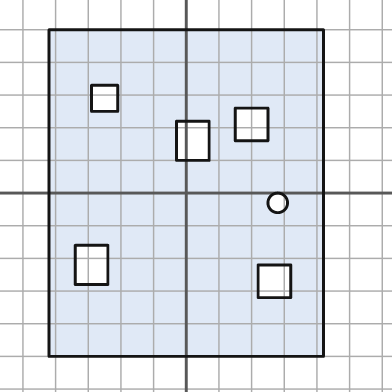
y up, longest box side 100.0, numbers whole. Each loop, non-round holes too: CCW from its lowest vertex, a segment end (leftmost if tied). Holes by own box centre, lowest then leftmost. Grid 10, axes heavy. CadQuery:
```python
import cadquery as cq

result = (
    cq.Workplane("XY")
    .moveTo(-42.0, -50.0)
    .lineTo(42.0, -50.0)
    .lineTo(42.0, 50.0)
    .lineTo(-42.0, 50.0)
    .close()
    .moveTo(22.0, -32.0)
    .lineTo(32.0, -32.0)
    .lineTo(32.0, -22.0)
    .lineTo(22.0, -22.0)
    .close()
    .moveTo(-34.0, -28.0)
    .lineTo(-24.0, -28.0)
    .lineTo(-24.0, -16.0)
    .lineTo(-34.0, -16.0)
    .close()
    .moveTo(28.0, -3.0)
    .circle(3.0)
    .moveTo(-3.0, 10.0)
    .lineTo(7.0, 10.0)
    .lineTo(7.0, 22.0)
    .lineTo(-3.0, 22.0)
    .close()
    .moveTo(15.0, 16.0)
    .lineTo(25.0, 16.0)
    .lineTo(25.0, 26.0)
    .lineTo(15.0, 26.0)
    .close()
    .moveTo(-29.0, 25.0)
    .lineTo(-21.0, 25.0)
    .lineTo(-21.0, 33.0)
    .lineTo(-29.0, 33.0)
    .close()
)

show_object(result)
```